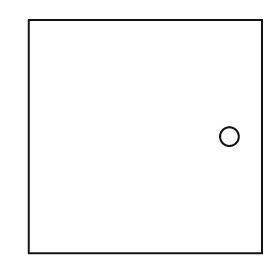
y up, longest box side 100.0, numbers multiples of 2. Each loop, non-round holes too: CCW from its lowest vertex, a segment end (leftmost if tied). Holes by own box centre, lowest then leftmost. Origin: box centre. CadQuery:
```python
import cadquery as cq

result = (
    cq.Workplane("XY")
    .moveTo(-50.0, -50.0)
    .lineTo(50.0, -50.0)
    .lineTo(50.0, 50.0)
    .lineTo(-50.0, 50.0)
    .close()
    .moveTo(36.0, 0.0)
    .circle(4.0)
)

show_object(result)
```